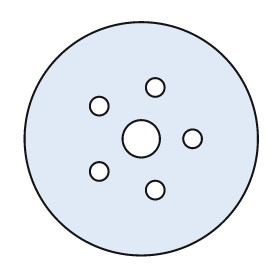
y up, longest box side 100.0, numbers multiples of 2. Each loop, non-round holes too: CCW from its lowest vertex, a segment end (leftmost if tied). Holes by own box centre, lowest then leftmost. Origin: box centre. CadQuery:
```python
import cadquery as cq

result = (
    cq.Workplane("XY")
    .moveTo(0.0, 0.0)
    .circle(50.0)
    .moveTo(6.0, -22.0)
    .circle(4.0)
    .moveTo(-18.0, -14.0)
    .circle(4.0)
    .moveTo(0.0, 0.0)
    .circle(8.0)
    .moveTo(22.0, 0.0)
    .circle(4.0)
    .moveTo(-18.0, 14.0)
    .circle(4.0)
    .moveTo(6.0, 22.0)
    .circle(4.0)
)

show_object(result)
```